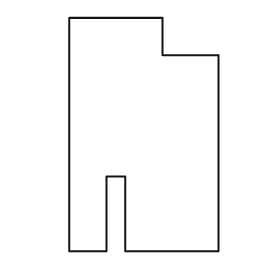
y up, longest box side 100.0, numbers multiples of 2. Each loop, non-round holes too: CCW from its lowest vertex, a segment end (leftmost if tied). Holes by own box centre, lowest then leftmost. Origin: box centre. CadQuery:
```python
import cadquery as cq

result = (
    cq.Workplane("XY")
    .moveTo(-32.0, -50.0)
    .lineTo(-16.0, -50.0)
    .lineTo(-16.0, -18.0)
    .lineTo(-8.0, -18.0)
    .lineTo(-8.0, -50.0)
    .lineTo(32.0, -50.0)
    .lineTo(32.0, 34.0)
    .lineTo(8.0, 34.0)
    .lineTo(8.0, 50.0)
    .lineTo(-32.0, 50.0)
    .close()
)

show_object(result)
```